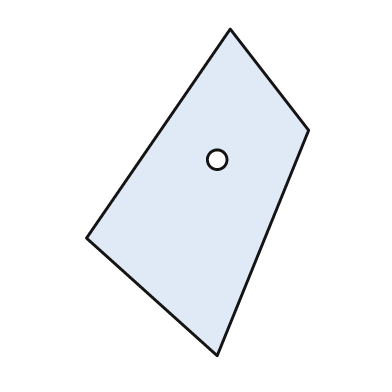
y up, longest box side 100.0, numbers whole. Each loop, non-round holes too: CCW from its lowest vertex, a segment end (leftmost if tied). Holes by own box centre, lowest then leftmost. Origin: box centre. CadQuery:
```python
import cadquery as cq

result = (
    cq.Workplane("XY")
    .moveTo(6.0, -50.0)
    .lineTo(34.0, 19.0)
    .lineTo(10.0, 50.0)
    .lineTo(-34.0, -14.0)
    .close()
    .moveTo(6.0, 10.0)
    .circle(3.0)
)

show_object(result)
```